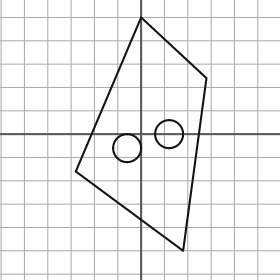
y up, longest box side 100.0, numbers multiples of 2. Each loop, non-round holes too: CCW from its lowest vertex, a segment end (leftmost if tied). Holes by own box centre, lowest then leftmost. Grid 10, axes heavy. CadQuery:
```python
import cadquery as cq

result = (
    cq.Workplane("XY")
    .moveTo(18.0, -50.0)
    .lineTo(28.0, 24.0)
    .lineTo(0.0, 50.0)
    .lineTo(-28.0, -16.0)
    .close()
    .moveTo(-6.0, -6.0)
    .circle(6.0)
    .moveTo(12.0, 0.0)
    .circle(6.0)
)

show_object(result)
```